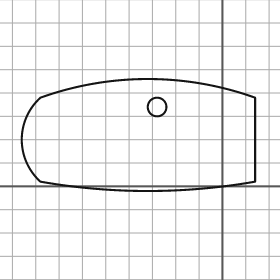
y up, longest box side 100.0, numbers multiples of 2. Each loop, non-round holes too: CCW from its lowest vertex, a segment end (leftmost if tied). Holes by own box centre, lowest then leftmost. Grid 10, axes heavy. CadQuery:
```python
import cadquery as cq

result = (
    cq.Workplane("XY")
    .moveTo(-78.0, 2.0)
    .threePointArc((-32.0, -2.0), (14.0, 2.0))
    .lineTo(14.0, 38.0)
    .threePointArc((-32.0, 46.0), (-78.0, 38.0))
    .threePointArc((-86.0, 20.0), (-78.0, 2.0))
    .close()
    .moveTo(-28.0, 34.0)
    .circle(4.0)
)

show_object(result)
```